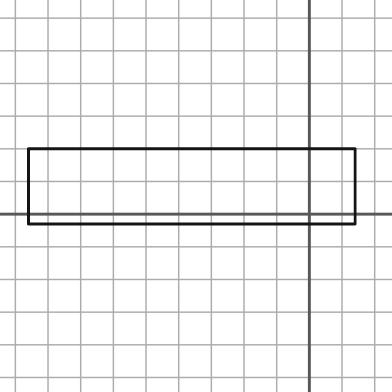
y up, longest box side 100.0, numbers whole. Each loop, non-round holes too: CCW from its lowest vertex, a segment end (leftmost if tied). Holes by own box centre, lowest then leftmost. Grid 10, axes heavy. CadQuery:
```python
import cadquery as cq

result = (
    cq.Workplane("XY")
    .moveTo(-86.0, -3.0)
    .lineTo(14.0, -3.0)
    .lineTo(14.0, 20.0)
    .lineTo(-86.0, 20.0)
    .close()
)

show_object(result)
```